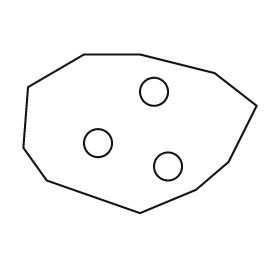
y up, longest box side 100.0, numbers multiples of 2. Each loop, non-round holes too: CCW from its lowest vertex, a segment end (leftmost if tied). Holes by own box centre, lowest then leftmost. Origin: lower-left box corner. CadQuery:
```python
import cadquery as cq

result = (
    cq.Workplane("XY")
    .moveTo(50.0, 0.0)
    .lineTo(74.0, 10.0)
    .lineTo(88.0, 22.0)
    .lineTo(100.0, 46.0)
    .lineTo(82.0, 60.0)
    .lineTo(50.0, 68.0)
    .lineTo(26.0, 68.0)
    .lineTo(2.0, 54.0)
    .lineTo(0.0, 28.0)
    .lineTo(10.0, 14.0)
    .close()
    .moveTo(62.0, 20.0)
    .circle(6.0)
    .moveTo(32.0, 30.0)
    .circle(6.0)
    .moveTo(56.0, 52.0)
    .circle(6.0)
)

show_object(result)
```